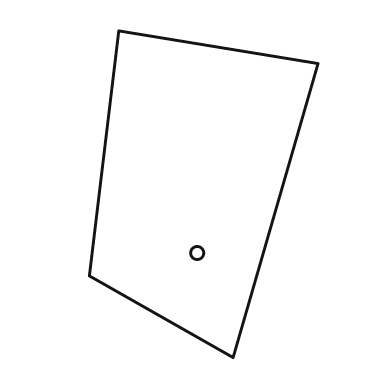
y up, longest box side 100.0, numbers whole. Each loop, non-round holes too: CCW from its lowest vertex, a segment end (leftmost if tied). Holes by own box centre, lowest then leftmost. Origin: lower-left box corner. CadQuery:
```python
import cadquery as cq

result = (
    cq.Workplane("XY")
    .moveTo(44.0, 0.0)
    .lineTo(70.0, 90.0)
    .lineTo(9.0, 100.0)
    .lineTo(0.0, 25.0)
    .close()
    .moveTo(33.0, 32.0)
    .circle(2.0)
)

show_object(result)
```